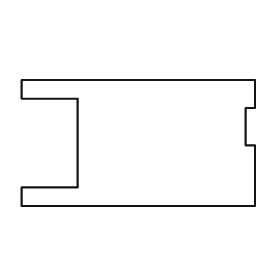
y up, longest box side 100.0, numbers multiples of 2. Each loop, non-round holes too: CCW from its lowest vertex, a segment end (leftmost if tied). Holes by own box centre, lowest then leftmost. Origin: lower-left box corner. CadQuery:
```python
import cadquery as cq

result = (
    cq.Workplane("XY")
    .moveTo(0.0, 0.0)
    .lineTo(100.0, 0.0)
    .lineTo(100.0, 26.0)
    .lineTo(96.0, 26.0)
    .lineTo(96.0, 42.0)
    .lineTo(100.0, 42.0)
    .lineTo(100.0, 54.0)
    .lineTo(0.0, 54.0)
    .lineTo(0.0, 46.0)
    .lineTo(24.0, 46.0)
    .lineTo(24.0, 8.0)
    .lineTo(0.0, 8.0)
    .close()
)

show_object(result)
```